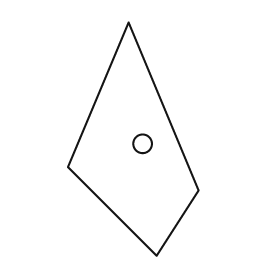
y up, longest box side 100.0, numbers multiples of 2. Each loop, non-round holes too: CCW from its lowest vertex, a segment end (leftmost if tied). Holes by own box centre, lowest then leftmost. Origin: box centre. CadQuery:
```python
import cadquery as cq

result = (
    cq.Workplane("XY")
    .moveTo(10.0, -50.0)
    .lineTo(28.0, -22.0)
    .lineTo(-2.0, 50.0)
    .lineTo(-28.0, -12.0)
    .close()
    .moveTo(4.0, -2.0)
    .circle(4.0)
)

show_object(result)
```